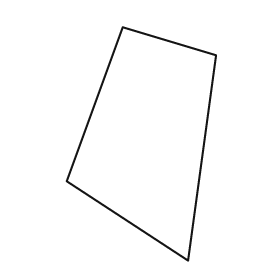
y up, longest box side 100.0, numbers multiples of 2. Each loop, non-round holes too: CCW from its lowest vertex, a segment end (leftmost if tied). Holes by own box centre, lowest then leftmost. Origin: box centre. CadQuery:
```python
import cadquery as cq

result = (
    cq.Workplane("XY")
    .moveTo(20.0, -50.0)
    .lineTo(32.0, 38.0)
    .lineTo(-8.0, 50.0)
    .lineTo(-32.0, -16.0)
    .close()
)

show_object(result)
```